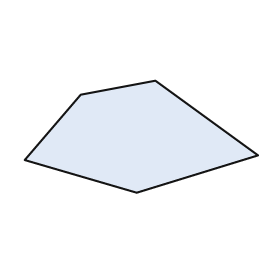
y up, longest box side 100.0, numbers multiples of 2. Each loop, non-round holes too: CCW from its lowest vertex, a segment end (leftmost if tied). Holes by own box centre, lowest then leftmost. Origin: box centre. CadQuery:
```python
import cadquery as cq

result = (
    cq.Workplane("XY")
    .moveTo(-2.0, -24.0)
    .lineTo(50.0, -8.0)
    .lineTo(6.0, 24.0)
    .lineTo(-26.0, 18.0)
    .lineTo(-50.0, -10.0)
    .close()
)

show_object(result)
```